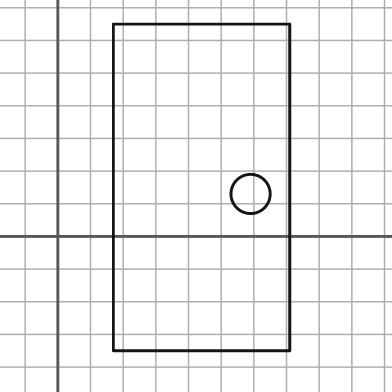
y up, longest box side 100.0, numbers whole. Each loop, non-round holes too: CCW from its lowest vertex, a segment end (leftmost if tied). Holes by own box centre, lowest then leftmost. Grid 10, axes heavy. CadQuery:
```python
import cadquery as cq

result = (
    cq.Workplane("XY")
    .moveTo(17.0, -35.0)
    .lineTo(71.0, -35.0)
    .lineTo(71.0, 65.0)
    .lineTo(17.0, 65.0)
    .close()
    .moveTo(59.0, 13.0)
    .circle(6.0)
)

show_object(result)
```